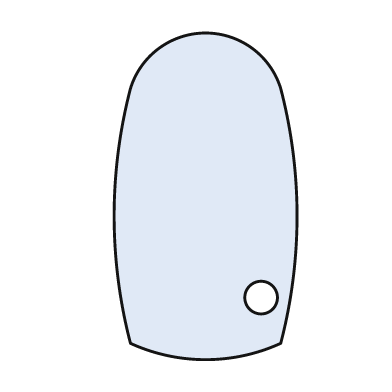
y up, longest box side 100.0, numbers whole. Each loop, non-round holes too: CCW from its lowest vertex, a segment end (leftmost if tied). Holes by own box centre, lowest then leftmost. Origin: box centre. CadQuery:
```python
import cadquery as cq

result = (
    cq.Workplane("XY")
    .moveTo(-23.0, -45.0)
    .threePointArc((0.0, -50.0), (23.0, -45.0))
    .threePointArc((28.0, -6.0), (23.0, 33.0))
    .threePointArc((0.0, 50.0), (-23.0, 33.0))
    .threePointArc((-28.0, -6.0), (-23.0, -45.0))
    .close()
    .moveTo(17.0, -31.0)
    .circle(5.0)
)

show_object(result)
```